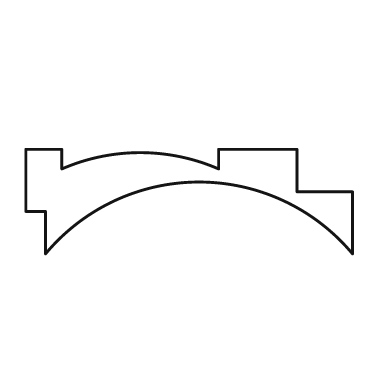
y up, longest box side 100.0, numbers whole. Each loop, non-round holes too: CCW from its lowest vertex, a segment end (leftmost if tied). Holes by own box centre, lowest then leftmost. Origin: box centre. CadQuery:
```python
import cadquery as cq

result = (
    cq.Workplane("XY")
    .moveTo(-44.0, -16.0)
    .threePointArc((3.0, 6.0), (50.0, -16.0))
    .lineTo(50.0, 3.0)
    .lineTo(33.0, 3.0)
    .lineTo(33.0, 16.0)
    .lineTo(9.0, 16.0)
    .lineTo(9.0, 10.0)
    .threePointArc((-15.0, 15.0), (-39.0, 10.0))
    .lineTo(-39.0, 16.0)
    .lineTo(-50.0, 16.0)
    .lineTo(-50.0, -3.0)
    .lineTo(-44.0, -3.0)
    .close()
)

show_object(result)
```